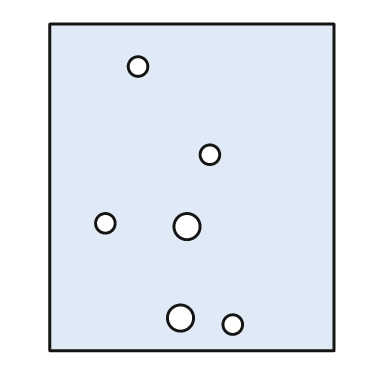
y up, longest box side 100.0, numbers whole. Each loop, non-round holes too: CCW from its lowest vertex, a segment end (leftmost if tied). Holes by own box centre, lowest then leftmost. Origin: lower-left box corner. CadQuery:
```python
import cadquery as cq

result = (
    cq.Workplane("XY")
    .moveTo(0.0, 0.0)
    .lineTo(87.0, 0.0)
    .lineTo(87.0, 100.0)
    .lineTo(0.0, 100.0)
    .close()
    .moveTo(56.0, 8.0)
    .circle(3.0)
    .moveTo(40.0, 10.0)
    .circle(4.0)
    .moveTo(42.0, 38.0)
    .circle(4.0)
    .moveTo(17.0, 39.0)
    .circle(3.0)
    .moveTo(49.0, 60.0)
    .circle(3.0)
    .moveTo(27.0, 87.0)
    .circle(3.0)
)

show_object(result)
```